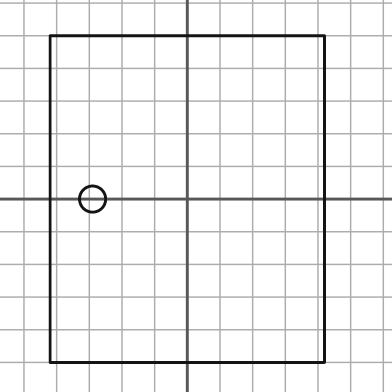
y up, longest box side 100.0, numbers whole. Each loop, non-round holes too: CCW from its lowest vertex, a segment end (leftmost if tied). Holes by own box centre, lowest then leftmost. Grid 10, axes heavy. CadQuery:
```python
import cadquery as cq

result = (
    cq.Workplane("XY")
    .moveTo(-42.0, -50.0)
    .lineTo(42.0, -50.0)
    .lineTo(42.0, 50.0)
    .lineTo(-42.0, 50.0)
    .close()
    .moveTo(-29.0, 0.0)
    .circle(4.0)
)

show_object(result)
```